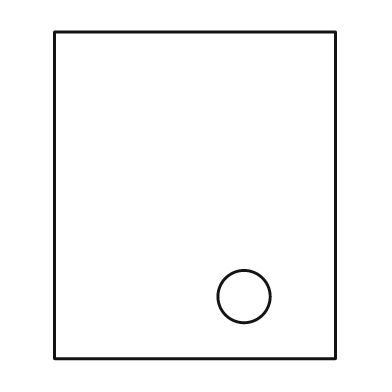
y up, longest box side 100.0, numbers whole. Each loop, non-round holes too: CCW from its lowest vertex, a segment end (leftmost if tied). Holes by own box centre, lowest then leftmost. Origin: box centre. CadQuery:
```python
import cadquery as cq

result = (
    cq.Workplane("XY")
    .moveTo(-43.0, -50.0)
    .lineTo(43.0, -50.0)
    .lineTo(43.0, 50.0)
    .lineTo(-43.0, 50.0)
    .close()
    .moveTo(15.0, -31.0)
    .circle(8.0)
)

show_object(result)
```